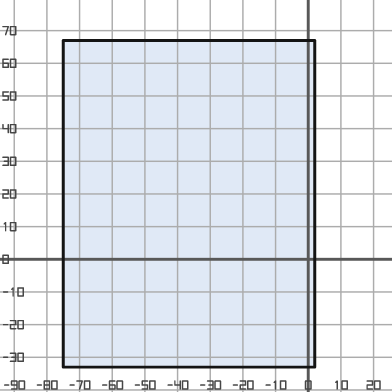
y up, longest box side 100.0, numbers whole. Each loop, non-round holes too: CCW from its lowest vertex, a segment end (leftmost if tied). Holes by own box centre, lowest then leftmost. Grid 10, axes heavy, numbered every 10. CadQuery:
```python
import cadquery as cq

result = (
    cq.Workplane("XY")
    .moveTo(-75.0, -33.0)
    .lineTo(2.0, -33.0)
    .lineTo(2.0, 67.0)
    .lineTo(-75.0, 67.0)
    .close()
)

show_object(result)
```